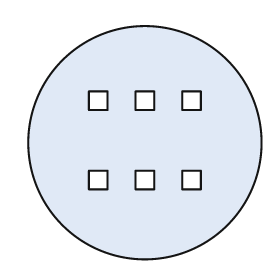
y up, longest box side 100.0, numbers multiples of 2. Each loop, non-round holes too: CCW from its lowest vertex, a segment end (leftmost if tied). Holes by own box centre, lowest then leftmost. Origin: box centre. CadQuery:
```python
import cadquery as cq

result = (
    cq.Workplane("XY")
    .moveTo(0.0, 0.0)
    .circle(50.0)
    .moveTo(-24.0, -20.0)
    .lineTo(-16.0, -20.0)
    .lineTo(-16.0, -12.0)
    .lineTo(-24.0, -12.0)
    .close()
    .moveTo(-4.0, -20.0)
    .lineTo(4.0, -20.0)
    .lineTo(4.0, -12.0)
    .lineTo(-4.0, -12.0)
    .close()
    .moveTo(16.0, -20.0)
    .lineTo(24.0, -20.0)
    .lineTo(24.0, -12.0)
    .lineTo(16.0, -12.0)
    .close()
    .moveTo(-24.0, 14.0)
    .lineTo(-16.0, 14.0)
    .lineTo(-16.0, 22.0)
    .lineTo(-24.0, 22.0)
    .close()
    .moveTo(-4.0, 14.0)
    .lineTo(4.0, 14.0)
    .lineTo(4.0, 22.0)
    .lineTo(-4.0, 22.0)
    .close()
    .moveTo(16.0, 14.0)
    .lineTo(24.0, 14.0)
    .lineTo(24.0, 22.0)
    .lineTo(16.0, 22.0)
    .close()
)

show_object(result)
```